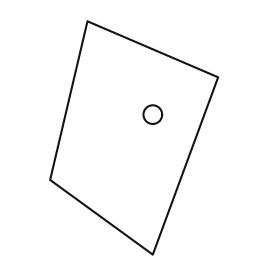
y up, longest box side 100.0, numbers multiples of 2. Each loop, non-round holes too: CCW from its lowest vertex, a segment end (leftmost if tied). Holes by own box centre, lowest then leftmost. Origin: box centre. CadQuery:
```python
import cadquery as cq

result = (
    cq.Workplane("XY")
    .moveTo(8.0, -50.0)
    .lineTo(36.0, 26.0)
    .lineTo(-20.0, 50.0)
    .lineTo(-36.0, -18.0)
    .close()
    .moveTo(8.0, 10.0)
    .circle(4.0)
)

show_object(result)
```